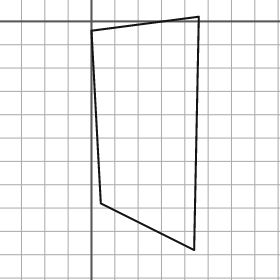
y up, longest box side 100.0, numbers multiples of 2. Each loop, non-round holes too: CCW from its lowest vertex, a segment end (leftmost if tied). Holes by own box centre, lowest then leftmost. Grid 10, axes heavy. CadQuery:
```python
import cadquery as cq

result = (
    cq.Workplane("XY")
    .moveTo(44.0, -98.0)
    .lineTo(46.0, 2.0)
    .lineTo(0.0, -4.0)
    .lineTo(4.0, -78.0)
    .close()
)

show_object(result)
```